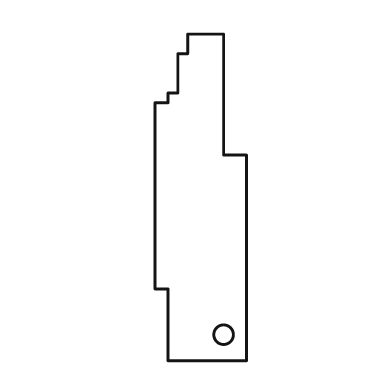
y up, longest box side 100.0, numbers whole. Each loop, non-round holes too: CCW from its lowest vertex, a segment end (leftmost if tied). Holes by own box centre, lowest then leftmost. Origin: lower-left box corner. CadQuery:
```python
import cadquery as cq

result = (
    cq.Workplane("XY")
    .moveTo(4.0, 0.0)
    .lineTo(28.0, 0.0)
    .lineTo(28.0, 63.0)
    .lineTo(21.0, 63.0)
    .lineTo(21.0, 100.0)
    .lineTo(10.0, 100.0)
    .lineTo(10.0, 94.0)
    .lineTo(7.0, 94.0)
    .lineTo(7.0, 82.0)
    .lineTo(4.0, 82.0)
    .lineTo(4.0, 79.0)
    .lineTo(0.0, 79.0)
    .lineTo(0.0, 22.0)
    .lineTo(4.0, 22.0)
    .close()
    .moveTo(21.0, 8.0)
    .circle(3.0)
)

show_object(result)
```